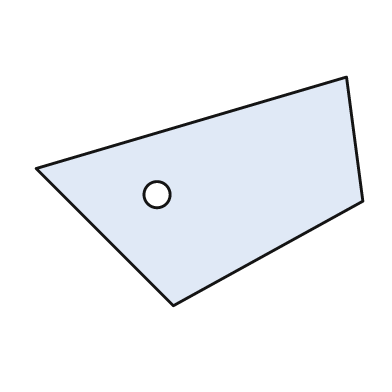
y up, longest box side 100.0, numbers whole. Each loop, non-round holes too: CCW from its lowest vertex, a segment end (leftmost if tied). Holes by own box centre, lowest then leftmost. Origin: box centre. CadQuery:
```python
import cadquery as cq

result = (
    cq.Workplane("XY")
    .moveTo(-8.0, -35.0)
    .lineTo(50.0, -3.0)
    .lineTo(45.0, 35.0)
    .lineTo(-50.0, 7.0)
    .close()
    .moveTo(-13.0, -1.0)
    .circle(4.0)
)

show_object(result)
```